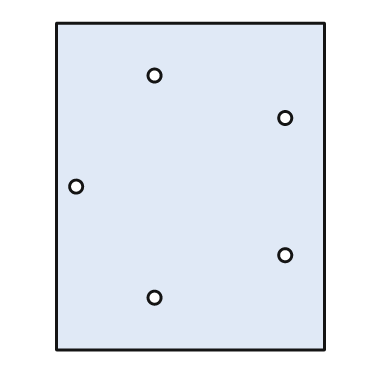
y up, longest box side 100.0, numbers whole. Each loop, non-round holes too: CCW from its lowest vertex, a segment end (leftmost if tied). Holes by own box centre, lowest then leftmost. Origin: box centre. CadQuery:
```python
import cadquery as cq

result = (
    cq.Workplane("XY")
    .moveTo(-41.0, -50.0)
    .lineTo(41.0, -50.0)
    .lineTo(41.0, 50.0)
    .lineTo(-41.0, 50.0)
    .close()
    .moveTo(-11.0, -34.0)
    .circle(2.0)
    .moveTo(29.0, -21.0)
    .circle(2.0)
    .moveTo(-35.0, 0.0)
    .circle(2.0)
    .moveTo(29.0, 21.0)
    .circle(2.0)
    .moveTo(-11.0, 34.0)
    .circle(2.0)
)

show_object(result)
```